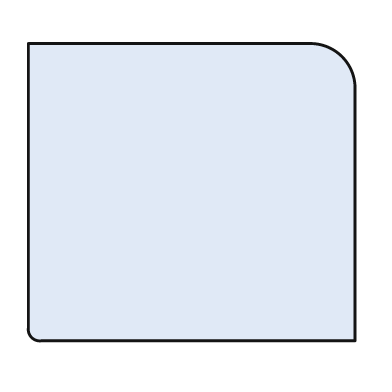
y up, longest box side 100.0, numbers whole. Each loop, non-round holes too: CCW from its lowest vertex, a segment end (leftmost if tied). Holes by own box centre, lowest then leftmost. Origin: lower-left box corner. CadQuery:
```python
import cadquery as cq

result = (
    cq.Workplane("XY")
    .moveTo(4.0, 0.0)
    .lineTo(100.0, 0.0)
    .lineTo(100.0, 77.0)
    .threePointArc((96.0, 87.0), (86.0, 91.0))
    .lineTo(0.0, 91.0)
    .lineTo(0.0, 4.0)
    .threePointArc((1.0, 1.0), (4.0, 0.0))
    .close()
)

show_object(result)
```